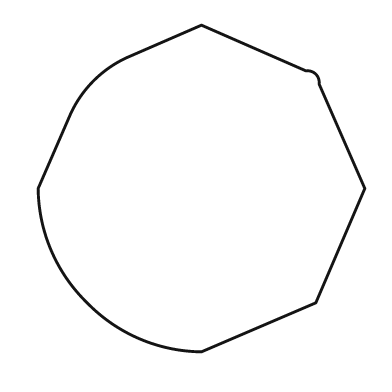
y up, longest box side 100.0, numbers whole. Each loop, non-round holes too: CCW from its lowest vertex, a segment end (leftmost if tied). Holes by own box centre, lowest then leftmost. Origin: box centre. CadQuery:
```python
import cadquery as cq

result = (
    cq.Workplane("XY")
    .moveTo(0.0, -50.0)
    .lineTo(35.0, -35.0)
    .lineTo(50.0, 0.0)
    .lineTo(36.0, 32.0)
    .threePointArc((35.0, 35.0), (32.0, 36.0))
    .lineTo(0.0, 50.0)
    .lineTo(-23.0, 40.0)
    .threePointArc((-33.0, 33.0), (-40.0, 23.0))
    .lineTo(-50.0, 0.0)
    .threePointArc((-46.0, -19.0), (-35.0, -35.0))
    .threePointArc((-19.0, -46.0), (0.0, -50.0))
    .close()
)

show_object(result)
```